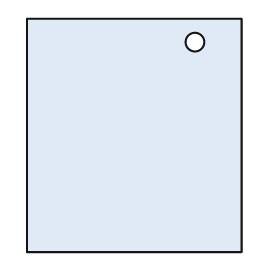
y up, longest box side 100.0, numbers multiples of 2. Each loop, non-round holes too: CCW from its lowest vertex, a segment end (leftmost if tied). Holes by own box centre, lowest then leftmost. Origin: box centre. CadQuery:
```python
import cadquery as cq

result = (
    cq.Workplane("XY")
    .moveTo(-46.0, -50.0)
    .lineTo(46.0, -50.0)
    .lineTo(46.0, 50.0)
    .lineTo(-46.0, 50.0)
    .close()
    .moveTo(26.0, 40.0)
    .circle(4.0)
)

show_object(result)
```